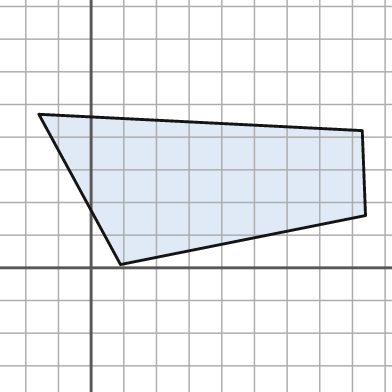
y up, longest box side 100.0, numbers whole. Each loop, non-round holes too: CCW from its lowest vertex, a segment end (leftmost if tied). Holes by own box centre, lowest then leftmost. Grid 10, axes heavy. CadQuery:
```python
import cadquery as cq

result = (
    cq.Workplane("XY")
    .moveTo(9.0, 1.0)
    .lineTo(84.0, 16.0)
    .lineTo(83.0, 42.0)
    .lineTo(-16.0, 47.0)
    .close()
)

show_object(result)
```